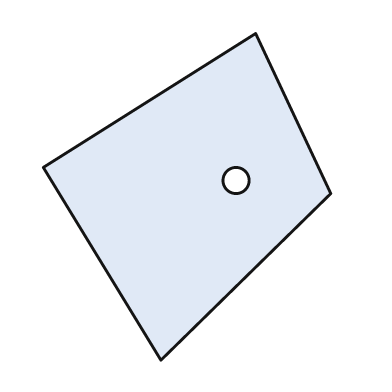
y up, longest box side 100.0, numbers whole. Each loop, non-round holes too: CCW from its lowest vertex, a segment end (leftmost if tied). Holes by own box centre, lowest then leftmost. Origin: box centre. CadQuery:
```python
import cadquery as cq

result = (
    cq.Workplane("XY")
    .moveTo(-8.0, -50.0)
    .lineTo(44.0, 1.0)
    .lineTo(21.0, 50.0)
    .lineTo(-44.0, 9.0)
    .close()
    .moveTo(15.0, 5.0)
    .circle(4.0)
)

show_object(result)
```